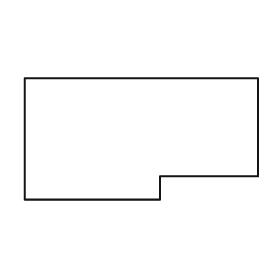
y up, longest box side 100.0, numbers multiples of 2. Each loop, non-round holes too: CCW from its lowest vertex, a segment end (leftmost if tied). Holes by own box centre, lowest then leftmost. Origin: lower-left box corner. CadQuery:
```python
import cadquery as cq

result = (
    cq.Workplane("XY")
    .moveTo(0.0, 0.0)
    .lineTo(58.0, 0.0)
    .lineTo(58.0, 10.0)
    .lineTo(100.0, 10.0)
    .lineTo(100.0, 52.0)
    .lineTo(0.0, 52.0)
    .close()
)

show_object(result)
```